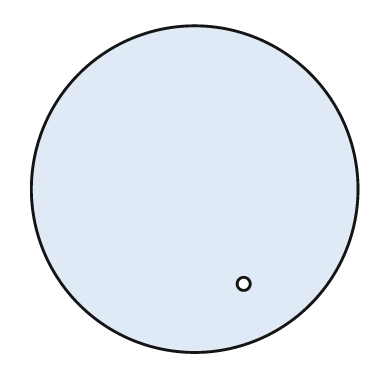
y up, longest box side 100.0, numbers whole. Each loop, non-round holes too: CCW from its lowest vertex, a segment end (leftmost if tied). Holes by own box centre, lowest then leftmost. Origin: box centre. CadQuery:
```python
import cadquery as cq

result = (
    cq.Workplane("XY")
    .moveTo(0.0, 0.0)
    .circle(50.0)
    .moveTo(15.0, -29.0)
    .circle(2.0)
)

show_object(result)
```